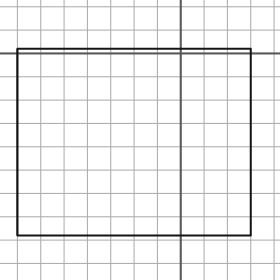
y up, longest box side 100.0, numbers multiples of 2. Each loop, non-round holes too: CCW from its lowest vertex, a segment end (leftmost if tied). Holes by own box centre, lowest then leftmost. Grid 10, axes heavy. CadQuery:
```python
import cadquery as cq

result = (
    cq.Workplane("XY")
    .moveTo(-70.0, -78.0)
    .lineTo(30.0, -78.0)
    .lineTo(30.0, 2.0)
    .lineTo(-70.0, 2.0)
    .close()
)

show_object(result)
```